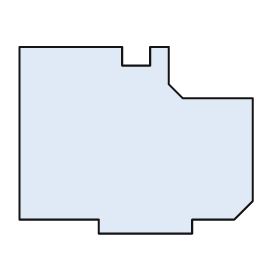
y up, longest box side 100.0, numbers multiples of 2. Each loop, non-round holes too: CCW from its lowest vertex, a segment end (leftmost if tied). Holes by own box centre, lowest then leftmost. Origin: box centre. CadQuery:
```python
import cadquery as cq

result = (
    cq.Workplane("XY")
    .moveTo(-16.0, -40.0)
    .lineTo(24.0, -40.0)
    .lineTo(24.0, -34.0)
    .lineTo(42.0, -34.0)
    .lineTo(50.0, -26.0)
    .lineTo(50.0, 18.0)
    .lineTo(20.0, 18.0)
    .lineTo(14.0, 24.0)
    .lineTo(14.0, 40.0)
    .lineTo(6.0, 40.0)
    .lineTo(6.0, 32.0)
    .lineTo(-6.0, 32.0)
    .lineTo(-6.0, 40.0)
    .lineTo(-50.0, 40.0)
    .lineTo(-50.0, -34.0)
    .lineTo(-16.0, -34.0)
    .close()
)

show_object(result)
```